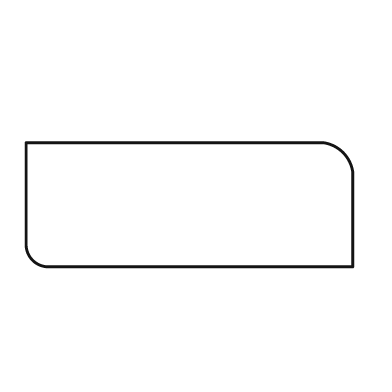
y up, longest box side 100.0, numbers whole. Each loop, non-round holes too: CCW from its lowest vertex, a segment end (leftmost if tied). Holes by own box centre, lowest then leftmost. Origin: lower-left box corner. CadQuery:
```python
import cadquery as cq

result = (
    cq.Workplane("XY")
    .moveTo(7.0, 0.0)
    .lineTo(100.0, 0.0)
    .lineTo(100.0, 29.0)
    .threePointArc((97.0, 35.0), (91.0, 38.0))
    .lineTo(0.0, 38.0)
    .lineTo(0.0, 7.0)
    .threePointArc((2.0, 2.0), (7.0, 0.0))
    .close()
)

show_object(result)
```